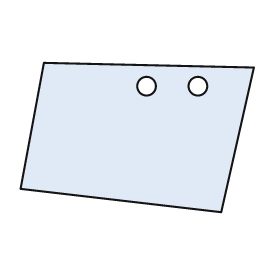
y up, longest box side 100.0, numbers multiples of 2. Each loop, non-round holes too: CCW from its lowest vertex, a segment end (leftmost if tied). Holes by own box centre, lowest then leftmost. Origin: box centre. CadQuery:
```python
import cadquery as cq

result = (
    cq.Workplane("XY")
    .moveTo(36.0, -32.0)
    .lineTo(50.0, 30.0)
    .lineTo(-40.0, 32.0)
    .lineTo(-50.0, -22.0)
    .close()
    .moveTo(4.0, 22.0)
    .circle(4.0)
    .moveTo(26.0, 22.0)
    .circle(4.0)
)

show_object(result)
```